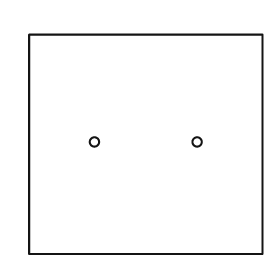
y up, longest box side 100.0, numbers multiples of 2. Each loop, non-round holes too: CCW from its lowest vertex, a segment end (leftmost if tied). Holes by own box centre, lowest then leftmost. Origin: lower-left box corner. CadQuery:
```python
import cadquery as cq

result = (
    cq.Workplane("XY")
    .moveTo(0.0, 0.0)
    .lineTo(100.0, 0.0)
    .lineTo(100.0, 94.0)
    .lineTo(0.0, 94.0)
    .close()
    .moveTo(28.0, 48.0)
    .circle(2.0)
    .moveTo(72.0, 48.0)
    .circle(2.0)
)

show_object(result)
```